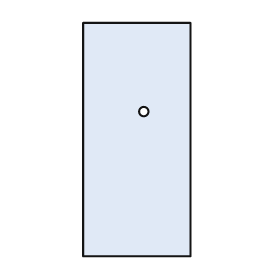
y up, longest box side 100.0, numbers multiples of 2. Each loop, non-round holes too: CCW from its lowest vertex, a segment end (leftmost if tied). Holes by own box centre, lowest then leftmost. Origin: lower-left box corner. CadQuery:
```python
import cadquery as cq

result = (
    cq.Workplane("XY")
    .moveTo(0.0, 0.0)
    .lineTo(46.0, 0.0)
    .lineTo(46.0, 100.0)
    .lineTo(0.0, 100.0)
    .close()
    .moveTo(26.0, 62.0)
    .circle(2.0)
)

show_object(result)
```